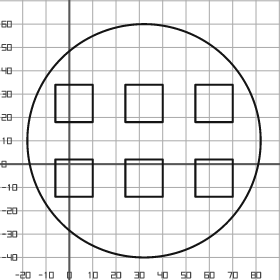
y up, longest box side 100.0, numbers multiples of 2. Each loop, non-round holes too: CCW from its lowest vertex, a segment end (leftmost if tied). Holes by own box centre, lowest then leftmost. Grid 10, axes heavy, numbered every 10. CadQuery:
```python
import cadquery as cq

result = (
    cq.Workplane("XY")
    .moveTo(32.0, 10.0)
    .circle(50.0)
    .moveTo(-6.0, -14.0)
    .lineTo(10.0, -14.0)
    .lineTo(10.0, 2.0)
    .lineTo(-6.0, 2.0)
    .close()
    .moveTo(24.0, -14.0)
    .lineTo(40.0, -14.0)
    .lineTo(40.0, 2.0)
    .lineTo(24.0, 2.0)
    .close()
    .moveTo(54.0, -14.0)
    .lineTo(70.0, -14.0)
    .lineTo(70.0, 2.0)
    .lineTo(54.0, 2.0)
    .close()
    .moveTo(-6.0, 18.0)
    .lineTo(10.0, 18.0)
    .lineTo(10.0, 34.0)
    .lineTo(-6.0, 34.0)
    .close()
    .moveTo(24.0, 18.0)
    .lineTo(40.0, 18.0)
    .lineTo(40.0, 34.0)
    .lineTo(24.0, 34.0)
    .close()
    .moveTo(54.0, 18.0)
    .lineTo(70.0, 18.0)
    .lineTo(70.0, 34.0)
    .lineTo(54.0, 34.0)
    .close()
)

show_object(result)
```